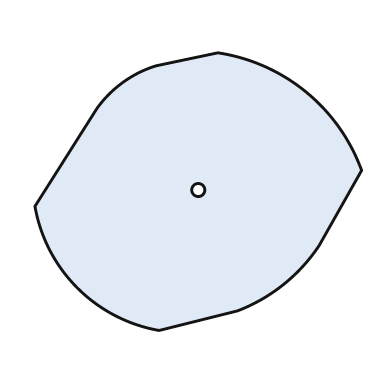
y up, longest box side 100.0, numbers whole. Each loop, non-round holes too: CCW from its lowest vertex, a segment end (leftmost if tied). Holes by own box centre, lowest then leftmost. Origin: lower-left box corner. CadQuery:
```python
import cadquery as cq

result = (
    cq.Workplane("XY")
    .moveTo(38.0, 0.0)
    .lineTo(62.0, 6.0)
    .threePointArc((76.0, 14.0), (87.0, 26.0))
    .lineTo(100.0, 49.0)
    .threePointArc((83.0, 73.0), (56.0, 85.0))
    .lineTo(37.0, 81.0)
    .threePointArc((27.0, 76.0), (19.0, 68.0))
    .lineTo(0.0, 38.0)
    .threePointArc((13.0, 13.0), (38.0, 0.0))
    .close()
    .moveTo(50.0, 43.0)
    .circle(2.0)
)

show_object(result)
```